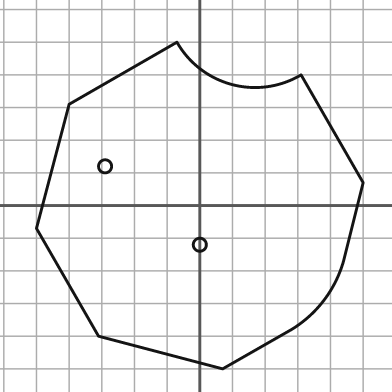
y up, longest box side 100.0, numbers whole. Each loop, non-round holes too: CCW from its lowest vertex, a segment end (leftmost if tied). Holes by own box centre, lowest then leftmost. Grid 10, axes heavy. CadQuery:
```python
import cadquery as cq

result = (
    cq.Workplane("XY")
    .moveTo(7.0, -50.0)
    .lineTo(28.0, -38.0)
    .threePointArc((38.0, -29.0), (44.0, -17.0))
    .lineTo(50.0, 7.0)
    .lineTo(31.0, 40.0)
    .threePointArc((10.0, 37.0), (-7.0, 50.0))
    .lineTo(-40.0, 31.0)
    .lineTo(-50.0, -7.0)
    .lineTo(-31.0, -40.0)
    .close()
    .moveTo(0.0, -12.0)
    .circle(2.0)
    .moveTo(-29.0, 12.0)
    .circle(2.0)
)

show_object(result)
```